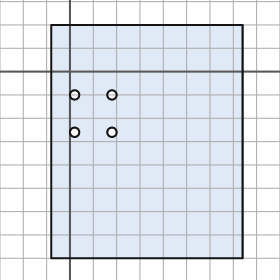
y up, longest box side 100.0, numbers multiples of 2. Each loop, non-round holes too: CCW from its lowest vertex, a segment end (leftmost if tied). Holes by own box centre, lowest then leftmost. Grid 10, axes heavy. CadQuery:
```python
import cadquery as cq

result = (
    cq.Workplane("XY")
    .moveTo(-8.0, -80.0)
    .lineTo(74.0, -80.0)
    .lineTo(74.0, 20.0)
    .lineTo(-8.0, 20.0)
    .close()
    .moveTo(2.0, -26.0)
    .circle(2.0)
    .moveTo(18.0, -26.0)
    .circle(2.0)
    .moveTo(2.0, -10.0)
    .circle(2.0)
    .moveTo(18.0, -10.0)
    .circle(2.0)
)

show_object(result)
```